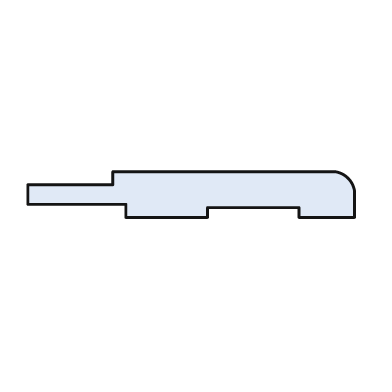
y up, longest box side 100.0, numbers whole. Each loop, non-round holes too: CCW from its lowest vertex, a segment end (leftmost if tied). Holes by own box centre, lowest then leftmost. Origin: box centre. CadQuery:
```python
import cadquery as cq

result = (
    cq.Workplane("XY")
    .moveTo(-20.0, -7.0)
    .lineTo(5.0, -7.0)
    .lineTo(5.0, -4.0)
    .lineTo(33.0, -4.0)
    .lineTo(33.0, -7.0)
    .lineTo(50.0, -7.0)
    .lineTo(50.0, 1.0)
    .threePointArc((48.0, 5.0), (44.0, 7.0))
    .lineTo(-24.0, 7.0)
    .lineTo(-24.0, 3.0)
    .lineTo(-50.0, 3.0)
    .lineTo(-50.0, -3.0)
    .lineTo(-20.0, -3.0)
    .close()
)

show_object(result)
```